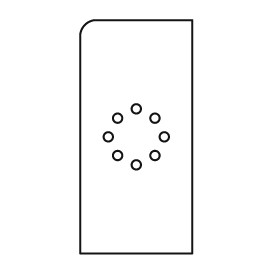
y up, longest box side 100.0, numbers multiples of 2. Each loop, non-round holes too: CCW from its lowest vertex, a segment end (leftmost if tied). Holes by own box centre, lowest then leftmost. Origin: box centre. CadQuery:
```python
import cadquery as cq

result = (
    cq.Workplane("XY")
    .moveTo(-24.0, -50.0)
    .lineTo(24.0, -50.0)
    .lineTo(24.0, 50.0)
    .lineTo(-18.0, 50.0)
    .threePointArc((-22.0, 48.0), (-24.0, 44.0))
    .close()
    .moveTo(0.0, -12.0)
    .circle(2.0)
    .moveTo(-8.0, -8.0)
    .circle(2.0)
    .moveTo(8.0, -8.0)
    .circle(2.0)
    .moveTo(-12.0, 0.0)
    .circle(2.0)
    .moveTo(12.0, 0.0)
    .circle(2.0)
    .moveTo(-8.0, 8.0)
    .circle(2.0)
    .moveTo(8.0, 8.0)
    .circle(2.0)
    .moveTo(0.0, 12.0)
    .circle(2.0)
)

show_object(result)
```